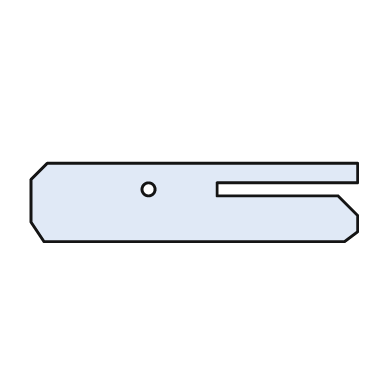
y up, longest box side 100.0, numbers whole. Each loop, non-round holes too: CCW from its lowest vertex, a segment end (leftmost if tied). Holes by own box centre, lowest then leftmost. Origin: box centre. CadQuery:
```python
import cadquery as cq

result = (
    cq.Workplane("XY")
    .moveTo(-46.0, -12.0)
    .lineTo(46.0, -12.0)
    .lineTo(50.0, -9.0)
    .lineTo(50.0, -4.0)
    .lineTo(44.0, 2.0)
    .lineTo(7.0, 2.0)
    .lineTo(7.0, 6.0)
    .lineTo(50.0, 6.0)
    .lineTo(50.0, 12.0)
    .lineTo(-45.0, 12.0)
    .lineTo(-50.0, 7.0)
    .lineTo(-50.0, -6.0)
    .close()
    .moveTo(-14.0, 4.0)
    .circle(2.0)
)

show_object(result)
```